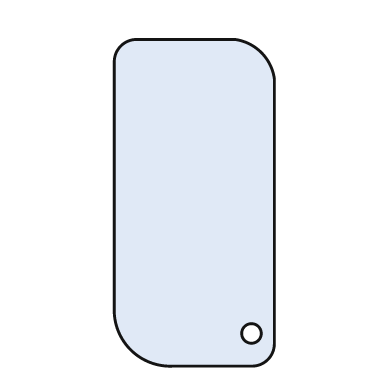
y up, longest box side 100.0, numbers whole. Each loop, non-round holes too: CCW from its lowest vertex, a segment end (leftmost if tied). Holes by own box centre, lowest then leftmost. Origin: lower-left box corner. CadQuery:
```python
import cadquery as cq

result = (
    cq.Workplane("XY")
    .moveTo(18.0, 0.0)
    .lineTo(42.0, 0.0)
    .threePointArc((47.0, 2.0), (49.0, 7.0))
    .lineTo(49.0, 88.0)
    .threePointArc((45.0, 96.0), (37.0, 100.0))
    .lineTo(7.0, 100.0)
    .threePointArc((2.0, 98.0), (0.0, 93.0))
    .lineTo(0.0, 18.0)
    .threePointArc((5.0, 5.0), (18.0, 0.0))
    .close()
    .moveTo(42.0, 10.0)
    .circle(3.0)
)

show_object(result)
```